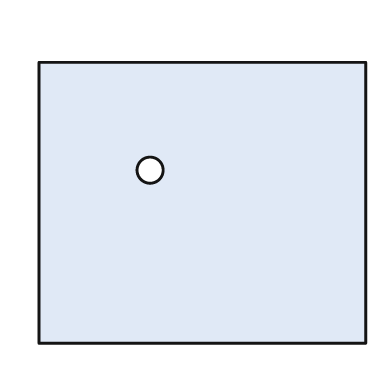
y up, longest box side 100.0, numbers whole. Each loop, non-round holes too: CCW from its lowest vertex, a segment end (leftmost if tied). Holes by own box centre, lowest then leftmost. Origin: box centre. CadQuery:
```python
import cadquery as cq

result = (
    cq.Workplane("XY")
    .moveTo(-50.0, -43.0)
    .lineTo(50.0, -43.0)
    .lineTo(50.0, 43.0)
    .lineTo(-50.0, 43.0)
    .close()
    .moveTo(-16.0, 10.0)
    .circle(4.0)
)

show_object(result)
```